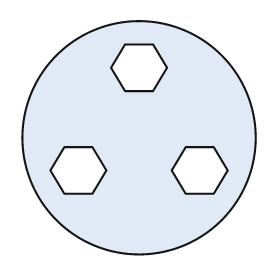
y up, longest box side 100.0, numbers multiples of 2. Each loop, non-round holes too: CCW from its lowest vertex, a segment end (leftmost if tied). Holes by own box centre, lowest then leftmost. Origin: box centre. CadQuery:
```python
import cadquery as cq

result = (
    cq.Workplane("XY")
    .moveTo(0.0, 0.0)
    .circle(50.0)
    .moveTo(-32.0, -24.0)
    .lineTo(-20.0, -24.0)
    .lineTo(-14.0, -14.0)
    .lineTo(-20.0, -4.0)
    .lineTo(-32.0, -4.0)
    .lineTo(-38.0, -14.0)
    .close()
    .moveTo(20.0, -24.0)
    .lineTo(32.0, -24.0)
    .lineTo(38.0, -14.0)
    .lineTo(32.0, -4.0)
    .lineTo(20.0, -4.0)
    .lineTo(14.0, -14.0)
    .close()
    .moveTo(-6.0, 20.0)
    .lineTo(6.0, 20.0)
    .lineTo(12.0, 30.0)
    .lineTo(6.0, 40.0)
    .lineTo(-6.0, 40.0)
    .lineTo(-12.0, 30.0)
    .close()
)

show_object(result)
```